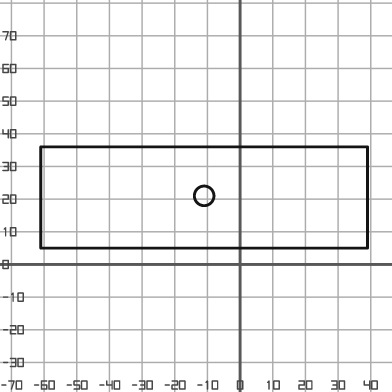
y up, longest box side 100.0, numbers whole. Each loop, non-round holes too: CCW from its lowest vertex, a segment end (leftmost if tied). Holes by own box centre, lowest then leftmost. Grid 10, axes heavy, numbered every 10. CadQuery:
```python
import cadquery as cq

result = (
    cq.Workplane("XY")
    .moveTo(-61.0, 5.0)
    .lineTo(39.0, 5.0)
    .lineTo(39.0, 36.0)
    .lineTo(-61.0, 36.0)
    .close()
    .moveTo(-11.0, 21.0)
    .circle(3.0)
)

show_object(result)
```